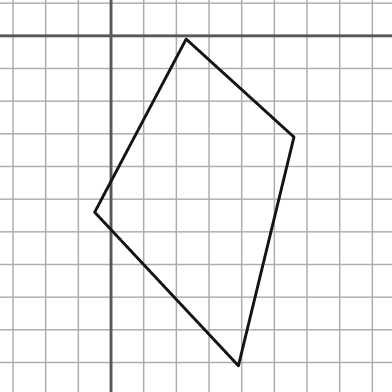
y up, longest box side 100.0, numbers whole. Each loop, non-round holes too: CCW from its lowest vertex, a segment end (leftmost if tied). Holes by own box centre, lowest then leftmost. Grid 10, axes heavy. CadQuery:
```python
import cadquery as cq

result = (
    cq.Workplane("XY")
    .moveTo(39.0, -101.0)
    .lineTo(56.0, -31.0)
    .lineTo(23.0, -1.0)
    .lineTo(-5.0, -54.0)
    .close()
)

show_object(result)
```